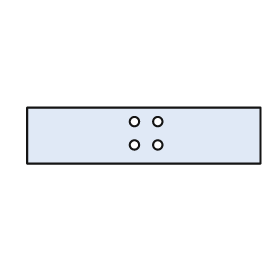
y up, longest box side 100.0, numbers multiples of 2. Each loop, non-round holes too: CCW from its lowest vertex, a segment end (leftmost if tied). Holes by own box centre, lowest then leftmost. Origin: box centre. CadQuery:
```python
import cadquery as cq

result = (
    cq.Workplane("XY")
    .moveTo(-50.0, -12.0)
    .lineTo(50.0, -12.0)
    .lineTo(50.0, 12.0)
    .lineTo(-50.0, 12.0)
    .close()
    .moveTo(-4.0, -4.0)
    .circle(2.0)
    .moveTo(6.0, -4.0)
    .circle(2.0)
    .moveTo(-4.0, 6.0)
    .circle(2.0)
    .moveTo(6.0, 6.0)
    .circle(2.0)
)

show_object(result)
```